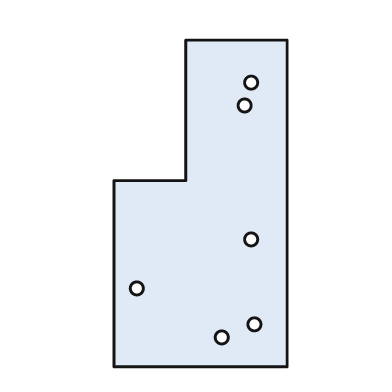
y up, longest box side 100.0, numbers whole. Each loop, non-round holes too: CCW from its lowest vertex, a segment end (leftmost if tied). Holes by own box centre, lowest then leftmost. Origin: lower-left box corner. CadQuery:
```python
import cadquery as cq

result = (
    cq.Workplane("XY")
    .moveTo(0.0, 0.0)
    .lineTo(53.0, 0.0)
    .lineTo(53.0, 100.0)
    .lineTo(22.0, 100.0)
    .lineTo(22.0, 57.0)
    .lineTo(0.0, 57.0)
    .close()
    .moveTo(33.0, 9.0)
    .circle(2.0)
    .moveTo(43.0, 13.0)
    .circle(2.0)
    .moveTo(7.0, 24.0)
    .circle(2.0)
    .moveTo(42.0, 39.0)
    .circle(2.0)
    .moveTo(40.0, 80.0)
    .circle(2.0)
    .moveTo(42.0, 87.0)
    .circle(2.0)
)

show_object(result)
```